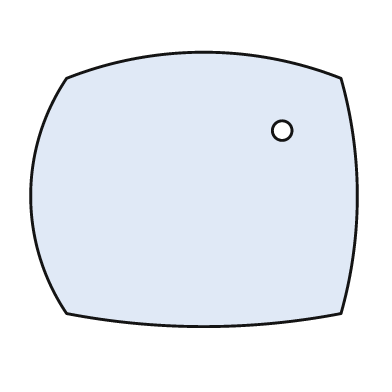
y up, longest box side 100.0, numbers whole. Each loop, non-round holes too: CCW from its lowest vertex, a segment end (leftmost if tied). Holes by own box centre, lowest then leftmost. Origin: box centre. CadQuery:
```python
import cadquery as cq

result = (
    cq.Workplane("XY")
    .moveTo(-39.0, -38.0)
    .threePointArc((3.0, -42.0), (45.0, -38.0))
    .threePointArc((50.0, -2.0), (45.0, 34.0))
    .threePointArc((3.0, 42.0), (-39.0, 34.0))
    .threePointArc((-50.0, -2.0), (-39.0, -38.0))
    .close()
    .moveTo(27.0, 18.0)
    .circle(3.0)
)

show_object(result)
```